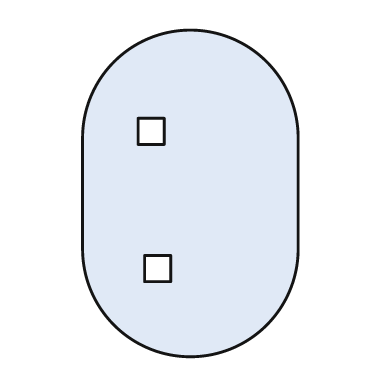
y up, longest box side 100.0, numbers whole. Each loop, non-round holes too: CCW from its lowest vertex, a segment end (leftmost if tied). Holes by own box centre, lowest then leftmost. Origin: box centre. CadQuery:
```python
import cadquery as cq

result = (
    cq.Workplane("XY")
    .moveTo(-33.0, -17.0)
    .threePointArc((0.0, -50.0), (33.0, -17.0))
    .lineTo(33.0, 17.0)
    .threePointArc((0.0, 50.0), (-33.0, 17.0))
    .close()
    .moveTo(-14.0, -27.0)
    .lineTo(-6.0, -27.0)
    .lineTo(-6.0, -19.0)
    .lineTo(-14.0, -19.0)
    .close()
    .moveTo(-16.0, 15.0)
    .lineTo(-8.0, 15.0)
    .lineTo(-8.0, 23.0)
    .lineTo(-16.0, 23.0)
    .close()
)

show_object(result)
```